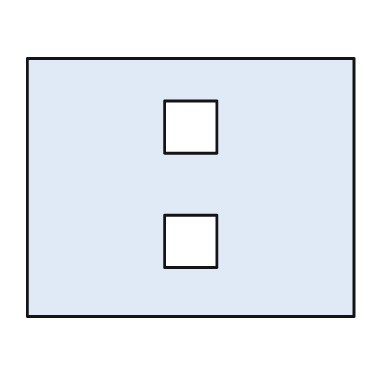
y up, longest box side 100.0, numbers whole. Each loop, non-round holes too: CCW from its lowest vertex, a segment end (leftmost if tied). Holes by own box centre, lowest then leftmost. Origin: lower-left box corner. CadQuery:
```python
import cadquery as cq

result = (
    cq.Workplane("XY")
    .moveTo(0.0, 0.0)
    .lineTo(100.0, 0.0)
    .lineTo(100.0, 79.0)
    .lineTo(0.0, 79.0)
    .close()
    .moveTo(42.0, 15.0)
    .lineTo(58.0, 15.0)
    .lineTo(58.0, 31.0)
    .lineTo(42.0, 31.0)
    .close()
    .moveTo(42.0, 50.0)
    .lineTo(58.0, 50.0)
    .lineTo(58.0, 66.0)
    .lineTo(42.0, 66.0)
    .close()
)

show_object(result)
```